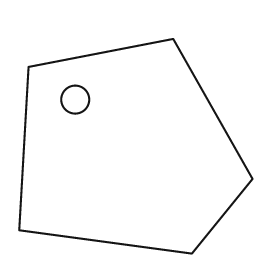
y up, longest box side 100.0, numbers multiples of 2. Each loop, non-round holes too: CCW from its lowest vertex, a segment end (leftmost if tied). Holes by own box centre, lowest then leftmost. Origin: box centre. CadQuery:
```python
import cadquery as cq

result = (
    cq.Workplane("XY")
    .moveTo(24.0, -46.0)
    .lineTo(50.0, -14.0)
    .lineTo(16.0, 46.0)
    .lineTo(-46.0, 34.0)
    .lineTo(-50.0, -36.0)
    .close()
    .moveTo(-26.0, 20.0)
    .circle(6.0)
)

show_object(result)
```